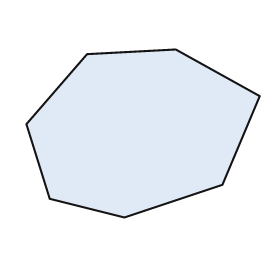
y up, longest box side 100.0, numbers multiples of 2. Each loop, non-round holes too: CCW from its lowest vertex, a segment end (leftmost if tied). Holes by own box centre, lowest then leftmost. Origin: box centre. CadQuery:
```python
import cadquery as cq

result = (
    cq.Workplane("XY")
    .moveTo(-8.0, -36.0)
    .lineTo(34.0, -22.0)
    .lineTo(50.0, 16.0)
    .lineTo(14.0, 36.0)
    .lineTo(-24.0, 34.0)
    .lineTo(-50.0, 4.0)
    .lineTo(-40.0, -28.0)
    .close()
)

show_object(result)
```